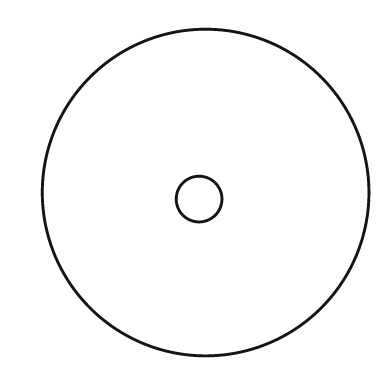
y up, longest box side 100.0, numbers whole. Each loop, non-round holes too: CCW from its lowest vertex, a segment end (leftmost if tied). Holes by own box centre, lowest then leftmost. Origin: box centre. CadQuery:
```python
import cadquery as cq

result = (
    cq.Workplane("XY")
    .moveTo(0.0, 0.0)
    .circle(50.0)
    .moveTo(-2.0, -2.0)
    .circle(7.0)
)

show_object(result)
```